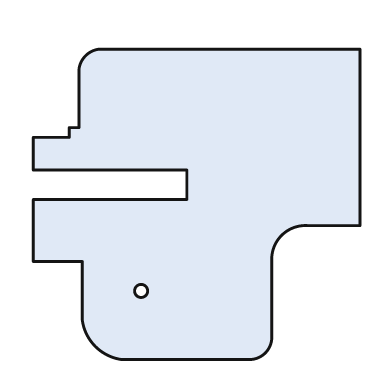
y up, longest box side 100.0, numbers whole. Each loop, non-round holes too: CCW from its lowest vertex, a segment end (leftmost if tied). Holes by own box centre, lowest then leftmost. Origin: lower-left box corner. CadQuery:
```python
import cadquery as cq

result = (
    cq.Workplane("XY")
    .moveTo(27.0, 0.0)
    .lineTo(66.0, 0.0)
    .threePointArc((71.0, 2.0), (73.0, 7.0))
    .lineTo(73.0, 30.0)
    .threePointArc((76.0, 38.0), (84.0, 41.0))
    .lineTo(100.0, 41.0)
    .lineTo(100.0, 95.0)
    .lineTo(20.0, 95.0)
    .threePointArc((16.0, 93.0), (14.0, 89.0))
    .lineTo(14.0, 71.0)
    .lineTo(11.0, 71.0)
    .lineTo(11.0, 68.0)
    .lineTo(0.0, 68.0)
    .lineTo(0.0, 58.0)
    .lineTo(47.0, 58.0)
    .lineTo(47.0, 49.0)
    .lineTo(0.0, 49.0)
    .lineTo(0.0, 30.0)
    .lineTo(15.0, 30.0)
    .lineTo(15.0, 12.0)
    .threePointArc((19.0, 4.0), (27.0, 0.0))
    .close()
    .moveTo(33.0, 21.0)
    .circle(2.0)
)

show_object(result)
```